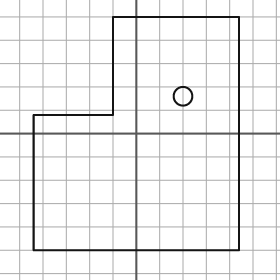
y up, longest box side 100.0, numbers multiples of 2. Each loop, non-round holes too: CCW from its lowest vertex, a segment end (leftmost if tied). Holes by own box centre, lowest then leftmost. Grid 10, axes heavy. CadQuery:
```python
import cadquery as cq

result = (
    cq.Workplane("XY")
    .moveTo(-44.0, -50.0)
    .lineTo(44.0, -50.0)
    .lineTo(44.0, 50.0)
    .lineTo(-10.0, 50.0)
    .lineTo(-10.0, 8.0)
    .lineTo(-44.0, 8.0)
    .close()
    .moveTo(20.0, 16.0)
    .circle(4.0)
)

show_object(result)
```